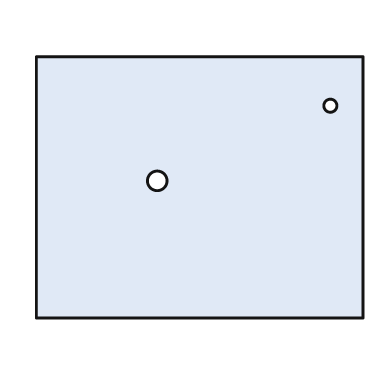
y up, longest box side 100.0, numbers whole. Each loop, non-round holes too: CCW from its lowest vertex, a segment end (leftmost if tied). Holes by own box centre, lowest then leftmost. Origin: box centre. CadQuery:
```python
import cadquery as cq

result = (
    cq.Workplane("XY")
    .moveTo(-50.0, -40.0)
    .lineTo(50.0, -40.0)
    .lineTo(50.0, 40.0)
    .lineTo(-50.0, 40.0)
    .close()
    .moveTo(-13.0, 2.0)
    .circle(3.0)
    .moveTo(40.0, 25.0)
    .circle(2.0)
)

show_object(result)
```